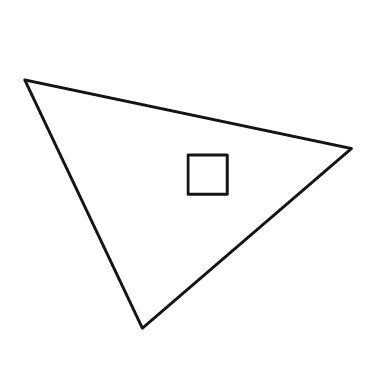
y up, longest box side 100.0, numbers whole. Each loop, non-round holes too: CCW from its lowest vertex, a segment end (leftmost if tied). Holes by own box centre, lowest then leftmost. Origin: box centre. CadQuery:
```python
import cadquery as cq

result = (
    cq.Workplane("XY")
    .moveTo(-14.0, -38.0)
    .lineTo(50.0, 17.0)
    .lineTo(-50.0, 38.0)
    .close()
    .moveTo(0.0, 3.0)
    .lineTo(12.0, 3.0)
    .lineTo(12.0, 15.0)
    .lineTo(0.0, 15.0)
    .close()
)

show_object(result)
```